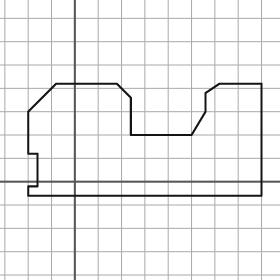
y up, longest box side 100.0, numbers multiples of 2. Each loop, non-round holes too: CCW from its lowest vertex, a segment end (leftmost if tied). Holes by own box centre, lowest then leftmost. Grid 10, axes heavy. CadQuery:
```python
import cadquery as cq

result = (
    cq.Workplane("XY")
    .moveTo(-20.0, -6.0)
    .lineTo(80.0, -6.0)
    .lineTo(80.0, 42.0)
    .lineTo(62.0, 42.0)
    .lineTo(56.0, 38.0)
    .lineTo(56.0, 30.0)
    .lineTo(50.0, 20.0)
    .lineTo(24.0, 20.0)
    .lineTo(24.0, 36.0)
    .lineTo(18.0, 42.0)
    .lineTo(-8.0, 42.0)
    .lineTo(-20.0, 30.0)
    .lineTo(-20.0, 12.0)
    .lineTo(-16.0, 12.0)
    .lineTo(-16.0, -2.0)
    .lineTo(-20.0, -2.0)
    .close()
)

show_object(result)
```